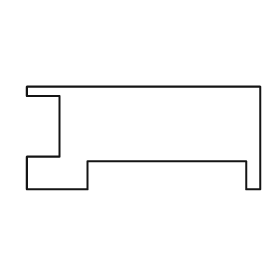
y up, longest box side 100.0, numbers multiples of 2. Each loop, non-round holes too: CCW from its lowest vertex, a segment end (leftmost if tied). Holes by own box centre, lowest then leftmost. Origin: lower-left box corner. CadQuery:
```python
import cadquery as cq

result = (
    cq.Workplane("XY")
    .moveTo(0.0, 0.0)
    .lineTo(26.0, 0.0)
    .lineTo(26.0, 12.0)
    .lineTo(94.0, 12.0)
    .lineTo(94.0, 0.0)
    .lineTo(100.0, 0.0)
    .lineTo(100.0, 44.0)
    .lineTo(0.0, 44.0)
    .lineTo(0.0, 40.0)
    .lineTo(14.0, 40.0)
    .lineTo(14.0, 14.0)
    .lineTo(0.0, 14.0)
    .close()
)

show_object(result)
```